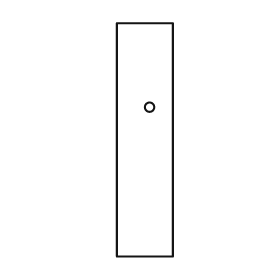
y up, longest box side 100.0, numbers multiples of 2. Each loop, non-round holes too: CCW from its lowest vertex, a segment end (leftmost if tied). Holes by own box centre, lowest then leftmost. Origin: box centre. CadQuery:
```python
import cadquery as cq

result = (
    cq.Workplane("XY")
    .moveTo(-12.0, -50.0)
    .lineTo(12.0, -50.0)
    .lineTo(12.0, 50.0)
    .lineTo(-12.0, 50.0)
    .close()
    .moveTo(2.0, 14.0)
    .circle(2.0)
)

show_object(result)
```